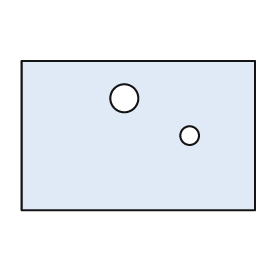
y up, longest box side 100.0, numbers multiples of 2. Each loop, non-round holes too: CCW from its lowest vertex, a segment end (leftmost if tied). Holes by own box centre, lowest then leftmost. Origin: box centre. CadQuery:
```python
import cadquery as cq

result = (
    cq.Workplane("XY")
    .moveTo(-50.0, -32.0)
    .lineTo(50.0, -32.0)
    .lineTo(50.0, 32.0)
    .lineTo(-50.0, 32.0)
    .close()
    .moveTo(22.0, 0.0)
    .circle(4.0)
    .moveTo(-6.0, 16.0)
    .circle(6.0)
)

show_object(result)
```